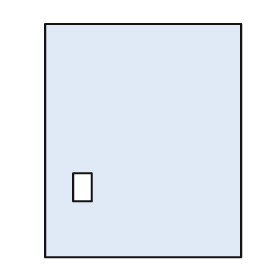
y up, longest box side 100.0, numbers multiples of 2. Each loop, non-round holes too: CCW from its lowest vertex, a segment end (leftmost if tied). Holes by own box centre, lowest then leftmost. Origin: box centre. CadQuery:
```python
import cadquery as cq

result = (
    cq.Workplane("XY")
    .moveTo(-42.0, -50.0)
    .lineTo(42.0, -50.0)
    .lineTo(42.0, 50.0)
    .lineTo(-42.0, 50.0)
    .close()
    .moveTo(-30.0, -26.0)
    .lineTo(-22.0, -26.0)
    .lineTo(-22.0, -14.0)
    .lineTo(-30.0, -14.0)
    .close()
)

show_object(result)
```